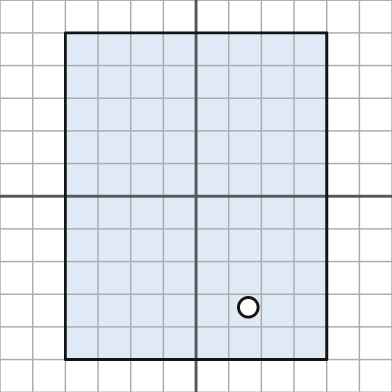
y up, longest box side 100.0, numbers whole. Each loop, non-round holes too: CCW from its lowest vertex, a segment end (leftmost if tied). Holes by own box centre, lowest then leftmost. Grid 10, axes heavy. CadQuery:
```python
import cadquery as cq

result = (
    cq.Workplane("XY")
    .moveTo(-40.0, -50.0)
    .lineTo(40.0, -50.0)
    .lineTo(40.0, 50.0)
    .lineTo(-40.0, 50.0)
    .close()
    .moveTo(16.0, -34.0)
    .circle(3.0)
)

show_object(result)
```